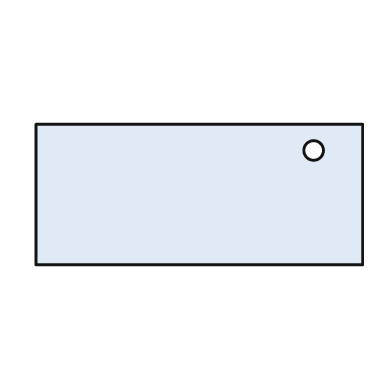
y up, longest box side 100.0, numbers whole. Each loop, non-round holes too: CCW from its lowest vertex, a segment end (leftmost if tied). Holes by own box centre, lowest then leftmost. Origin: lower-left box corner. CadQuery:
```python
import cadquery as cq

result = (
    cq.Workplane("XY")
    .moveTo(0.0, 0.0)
    .lineTo(100.0, 0.0)
    .lineTo(100.0, 43.0)
    .lineTo(0.0, 43.0)
    .close()
    .moveTo(85.0, 35.0)
    .circle(3.0)
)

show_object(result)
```